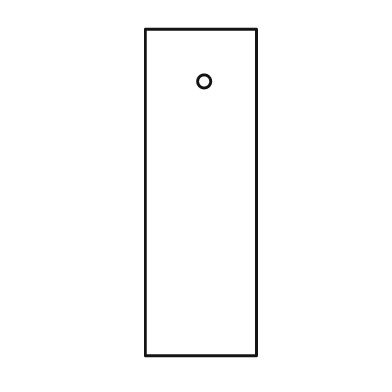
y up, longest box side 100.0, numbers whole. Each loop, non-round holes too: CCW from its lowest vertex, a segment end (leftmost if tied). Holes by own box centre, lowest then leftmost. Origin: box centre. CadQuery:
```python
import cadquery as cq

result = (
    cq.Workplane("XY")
    .moveTo(-17.0, -50.0)
    .lineTo(17.0, -50.0)
    .lineTo(17.0, 50.0)
    .lineTo(-17.0, 50.0)
    .close()
    .moveTo(1.0, 34.0)
    .circle(2.0)
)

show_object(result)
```